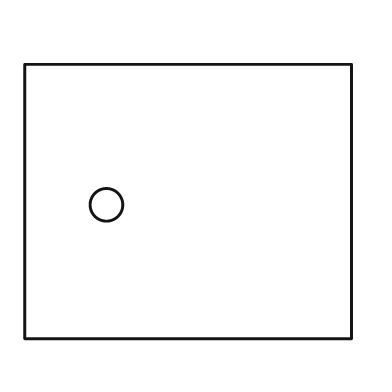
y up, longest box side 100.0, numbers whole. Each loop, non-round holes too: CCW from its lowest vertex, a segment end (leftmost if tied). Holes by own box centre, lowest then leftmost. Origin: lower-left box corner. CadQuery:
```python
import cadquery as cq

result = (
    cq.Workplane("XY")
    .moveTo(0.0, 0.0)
    .lineTo(100.0, 0.0)
    .lineTo(100.0, 84.0)
    .lineTo(0.0, 84.0)
    .close()
    .moveTo(25.0, 41.0)
    .circle(5.0)
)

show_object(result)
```